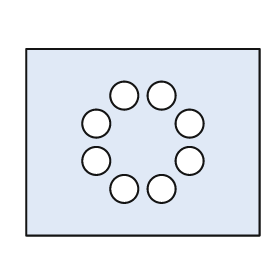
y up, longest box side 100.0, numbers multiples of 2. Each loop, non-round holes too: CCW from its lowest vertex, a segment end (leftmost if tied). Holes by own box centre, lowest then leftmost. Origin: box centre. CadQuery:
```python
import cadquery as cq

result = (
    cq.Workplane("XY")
    .moveTo(-50.0, -40.0)
    .lineTo(50.0, -40.0)
    .lineTo(50.0, 40.0)
    .lineTo(-50.0, 40.0)
    .close()
    .moveTo(-8.0, -20.0)
    .circle(6.0)
    .moveTo(8.0, -20.0)
    .circle(6.0)
    .moveTo(-20.0, -8.0)
    .circle(6.0)
    .moveTo(20.0, -8.0)
    .circle(6.0)
    .moveTo(-20.0, 8.0)
    .circle(6.0)
    .moveTo(20.0, 8.0)
    .circle(6.0)
    .moveTo(-8.0, 20.0)
    .circle(6.0)
    .moveTo(8.0, 20.0)
    .circle(6.0)
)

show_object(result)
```